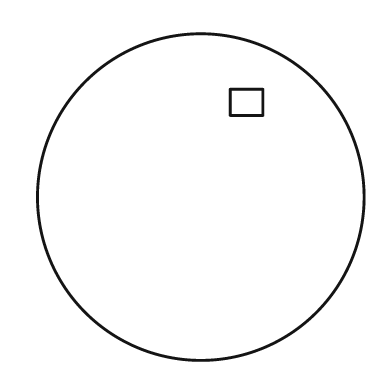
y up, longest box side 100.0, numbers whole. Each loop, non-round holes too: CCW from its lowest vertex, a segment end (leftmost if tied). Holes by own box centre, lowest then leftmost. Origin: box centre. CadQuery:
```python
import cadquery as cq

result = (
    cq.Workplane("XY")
    .moveTo(0.0, 0.0)
    .circle(50.0)
    .moveTo(9.0, 25.0)
    .lineTo(19.0, 25.0)
    .lineTo(19.0, 33.0)
    .lineTo(9.0, 33.0)
    .close()
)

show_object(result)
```